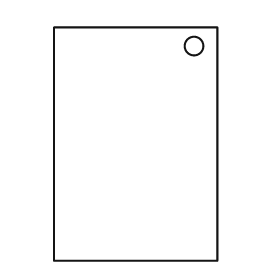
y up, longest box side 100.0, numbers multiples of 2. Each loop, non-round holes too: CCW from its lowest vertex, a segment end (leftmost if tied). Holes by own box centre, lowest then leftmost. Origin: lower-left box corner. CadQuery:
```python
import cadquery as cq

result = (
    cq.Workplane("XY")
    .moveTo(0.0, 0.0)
    .lineTo(70.0, 0.0)
    .lineTo(70.0, 100.0)
    .lineTo(0.0, 100.0)
    .close()
    .moveTo(60.0, 92.0)
    .circle(4.0)
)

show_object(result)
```